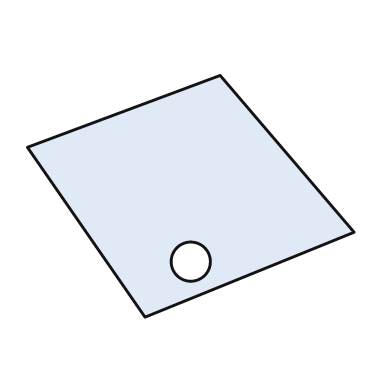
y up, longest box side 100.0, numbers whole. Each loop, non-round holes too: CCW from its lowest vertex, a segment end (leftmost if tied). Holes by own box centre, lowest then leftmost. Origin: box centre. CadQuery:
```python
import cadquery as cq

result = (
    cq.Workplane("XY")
    .moveTo(-14.0, -37.0)
    .lineTo(50.0, -11.0)
    .lineTo(9.0, 37.0)
    .lineTo(-50.0, 15.0)
    .close()
    .moveTo(0.0, -20.0)
    .circle(6.0)
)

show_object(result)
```